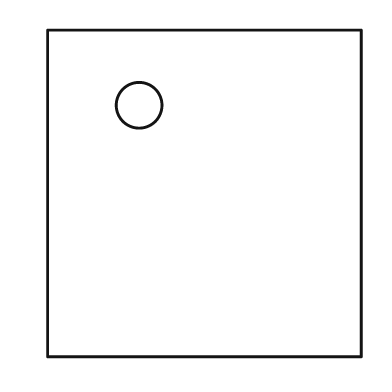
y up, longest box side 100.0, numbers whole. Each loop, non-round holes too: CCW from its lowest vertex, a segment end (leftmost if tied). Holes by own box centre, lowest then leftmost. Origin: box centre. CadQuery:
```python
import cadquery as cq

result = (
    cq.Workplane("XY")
    .moveTo(-48.0, -50.0)
    .lineTo(48.0, -50.0)
    .lineTo(48.0, 50.0)
    .lineTo(-48.0, 50.0)
    .close()
    .moveTo(-20.0, 27.0)
    .circle(7.0)
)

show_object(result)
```